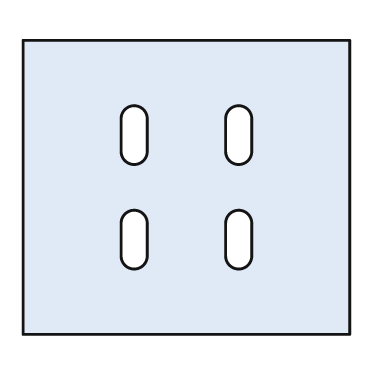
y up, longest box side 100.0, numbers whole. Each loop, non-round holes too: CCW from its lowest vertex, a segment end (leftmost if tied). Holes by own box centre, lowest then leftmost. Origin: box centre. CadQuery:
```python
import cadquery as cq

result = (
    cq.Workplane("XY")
    .moveTo(-50.0, -45.0)
    .lineTo(50.0, -45.0)
    .lineTo(50.0, 45.0)
    .lineTo(-50.0, 45.0)
    .close()
    .moveTo(-20.0, -21.0)
    .threePointArc((-16.0, -25.0), (-12.0, -21.0))
    .lineTo(-12.0, -11.0)
    .threePointArc((-16.0, -7.0), (-20.0, -11.0))
    .close()
    .moveTo(12.0, -21.0)
    .threePointArc((16.0, -25.0), (20.0, -21.0))
    .lineTo(20.0, -11.0)
    .threePointArc((16.0, -7.0), (12.0, -11.0))
    .close()
    .moveTo(-20.0, 11.0)
    .threePointArc((-16.0, 7.0), (-12.0, 11.0))
    .lineTo(-12.0, 21.0)
    .threePointArc((-16.0, 25.0), (-20.0, 21.0))
    .close()
    .moveTo(12.0, 11.0)
    .threePointArc((16.0, 7.0), (20.0, 11.0))
    .lineTo(20.0, 21.0)
    .threePointArc((16.0, 25.0), (12.0, 21.0))
    .close()
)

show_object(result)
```